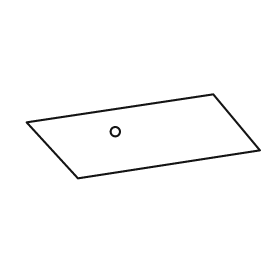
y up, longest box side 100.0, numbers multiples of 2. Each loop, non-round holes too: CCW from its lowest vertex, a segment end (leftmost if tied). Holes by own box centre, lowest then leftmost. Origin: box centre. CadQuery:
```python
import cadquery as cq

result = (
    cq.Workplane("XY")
    .moveTo(-28.0, -18.0)
    .lineTo(50.0, -6.0)
    .lineTo(30.0, 18.0)
    .lineTo(-50.0, 6.0)
    .close()
    .moveTo(-12.0, 2.0)
    .circle(2.0)
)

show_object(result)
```